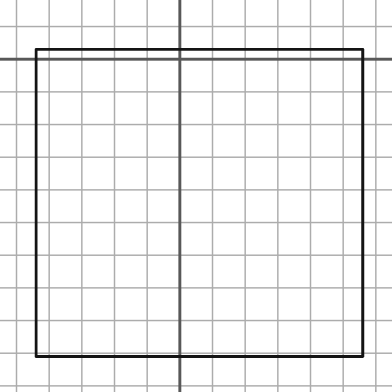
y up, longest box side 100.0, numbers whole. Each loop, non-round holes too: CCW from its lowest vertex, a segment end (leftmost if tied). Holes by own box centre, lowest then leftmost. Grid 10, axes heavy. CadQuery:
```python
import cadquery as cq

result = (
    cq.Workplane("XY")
    .moveTo(-44.0, -91.0)
    .lineTo(56.0, -91.0)
    .lineTo(56.0, 3.0)
    .lineTo(-44.0, 3.0)
    .close()
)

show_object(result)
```